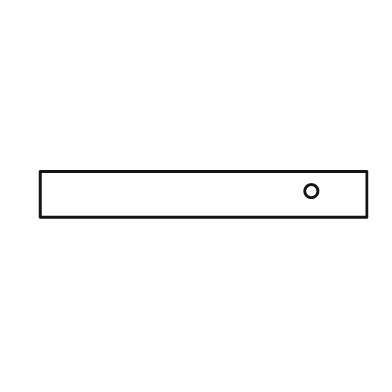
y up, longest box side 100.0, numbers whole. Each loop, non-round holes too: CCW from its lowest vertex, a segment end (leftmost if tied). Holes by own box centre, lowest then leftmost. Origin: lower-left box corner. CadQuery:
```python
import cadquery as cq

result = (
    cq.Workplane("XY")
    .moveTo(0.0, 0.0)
    .lineTo(100.0, 0.0)
    .lineTo(100.0, 14.0)
    .lineTo(0.0, 14.0)
    .close()
    .moveTo(83.0, 8.0)
    .circle(2.0)
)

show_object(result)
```